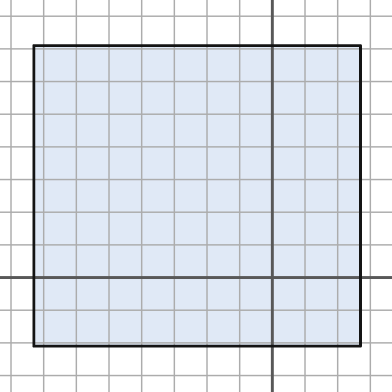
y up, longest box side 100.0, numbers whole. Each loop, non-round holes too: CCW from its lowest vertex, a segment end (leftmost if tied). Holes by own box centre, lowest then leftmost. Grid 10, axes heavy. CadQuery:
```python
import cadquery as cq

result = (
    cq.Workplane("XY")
    .moveTo(-73.0, -21.0)
    .lineTo(27.0, -21.0)
    .lineTo(27.0, 71.0)
    .lineTo(-73.0, 71.0)
    .close()
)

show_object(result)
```